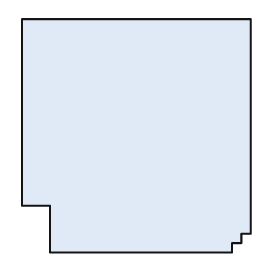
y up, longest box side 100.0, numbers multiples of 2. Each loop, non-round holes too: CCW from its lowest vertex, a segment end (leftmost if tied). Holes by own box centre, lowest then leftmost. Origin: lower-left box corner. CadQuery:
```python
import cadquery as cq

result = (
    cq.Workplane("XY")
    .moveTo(12.0, 0.0)
    .lineTo(90.0, 0.0)
    .lineTo(90.0, 4.0)
    .lineTo(94.0, 4.0)
    .lineTo(94.0, 8.0)
    .lineTo(98.0, 8.0)
    .lineTo(98.0, 100.0)
    .lineTo(0.0, 100.0)
    .lineTo(0.0, 20.0)
    .lineTo(12.0, 20.0)
    .close()
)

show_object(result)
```